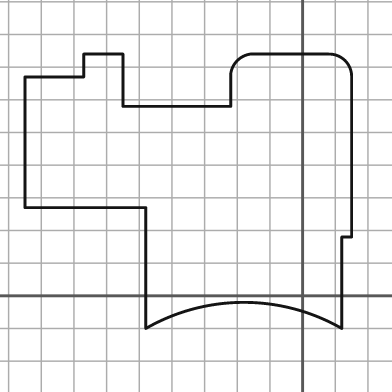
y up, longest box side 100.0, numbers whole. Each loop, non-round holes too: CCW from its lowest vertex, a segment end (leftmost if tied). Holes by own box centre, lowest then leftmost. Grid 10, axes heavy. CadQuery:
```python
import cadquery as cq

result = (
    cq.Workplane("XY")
    .moveTo(-48.0, -10.0)
    .threePointArc((-18.0, -2.0), (12.0, -10.0))
    .lineTo(12.0, 18.0)
    .lineTo(15.0, 18.0)
    .lineTo(15.0, 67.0)
    .threePointArc((13.0, 72.0), (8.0, 74.0))
    .lineTo(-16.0, 74.0)
    .threePointArc((-20.0, 72.0), (-22.0, 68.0))
    .lineTo(-22.0, 58.0)
    .lineTo(-55.0, 58.0)
    .lineTo(-55.0, 74.0)
    .lineTo(-67.0, 74.0)
    .lineTo(-67.0, 67.0)
    .lineTo(-85.0, 67.0)
    .lineTo(-85.0, 27.0)
    .lineTo(-48.0, 27.0)
    .close()
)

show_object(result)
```